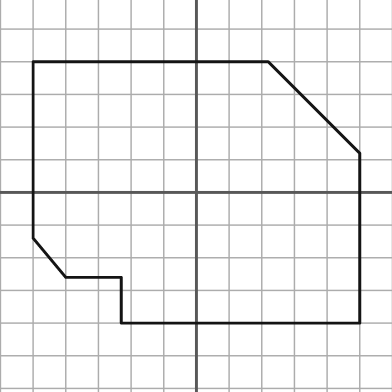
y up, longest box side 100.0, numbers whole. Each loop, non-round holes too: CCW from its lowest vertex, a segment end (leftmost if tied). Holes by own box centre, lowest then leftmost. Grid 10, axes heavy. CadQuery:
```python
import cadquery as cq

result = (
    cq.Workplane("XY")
    .moveTo(-23.0, -40.0)
    .lineTo(50.0, -40.0)
    .lineTo(50.0, 12.0)
    .lineTo(22.0, 40.0)
    .lineTo(-50.0, 40.0)
    .lineTo(-50.0, -14.0)
    .lineTo(-40.0, -26.0)
    .lineTo(-23.0, -26.0)
    .close()
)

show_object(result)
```